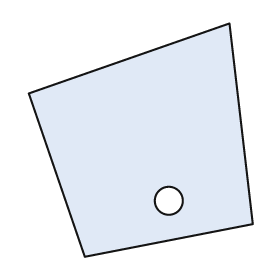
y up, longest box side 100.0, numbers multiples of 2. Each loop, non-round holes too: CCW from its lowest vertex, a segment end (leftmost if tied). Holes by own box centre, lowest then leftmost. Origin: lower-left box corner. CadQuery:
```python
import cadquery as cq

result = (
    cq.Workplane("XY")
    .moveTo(24.0, 0.0)
    .lineTo(96.0, 14.0)
    .lineTo(86.0, 100.0)
    .lineTo(0.0, 70.0)
    .close()
    .moveTo(60.0, 24.0)
    .circle(6.0)
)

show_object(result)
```